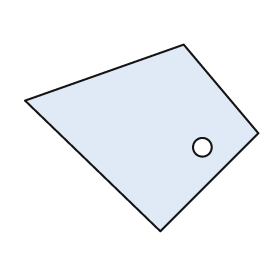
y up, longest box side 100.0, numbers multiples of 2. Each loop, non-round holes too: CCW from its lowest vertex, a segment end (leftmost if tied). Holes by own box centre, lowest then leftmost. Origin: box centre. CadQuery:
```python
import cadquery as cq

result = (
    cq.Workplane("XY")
    .moveTo(8.0, -40.0)
    .lineTo(50.0, 2.0)
    .lineTo(18.0, 40.0)
    .lineTo(-50.0, 16.0)
    .close()
    .moveTo(26.0, -4.0)
    .circle(4.0)
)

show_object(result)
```